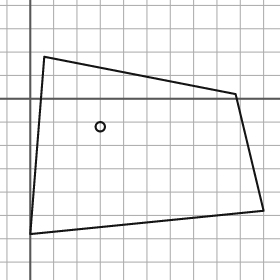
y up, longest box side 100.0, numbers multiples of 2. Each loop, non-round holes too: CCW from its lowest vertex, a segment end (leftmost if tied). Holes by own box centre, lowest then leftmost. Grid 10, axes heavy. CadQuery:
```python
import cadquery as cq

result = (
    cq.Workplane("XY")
    .moveTo(0.0, -58.0)
    .lineTo(100.0, -48.0)
    .lineTo(88.0, 2.0)
    .lineTo(6.0, 18.0)
    .close()
    .moveTo(30.0, -12.0)
    .circle(2.0)
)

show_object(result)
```